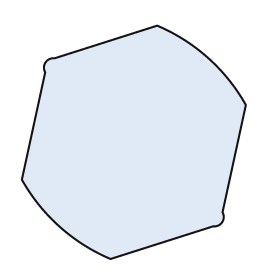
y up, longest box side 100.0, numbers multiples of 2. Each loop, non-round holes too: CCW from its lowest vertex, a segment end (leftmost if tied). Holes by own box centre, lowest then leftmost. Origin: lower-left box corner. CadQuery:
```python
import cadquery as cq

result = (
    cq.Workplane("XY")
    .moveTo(38.0, 0.0)
    .lineTo(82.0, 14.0)
    .threePointArc((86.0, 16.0), (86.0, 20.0))
    .lineTo(96.0, 66.0)
    .threePointArc((80.0, 86.0), (58.0, 100.0))
    .lineTo(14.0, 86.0)
    .threePointArc((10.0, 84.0), (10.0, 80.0))
    .lineTo(0.0, 34.0)
    .threePointArc((16.0, 14.0), (38.0, 0.0))
    .close()
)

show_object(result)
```